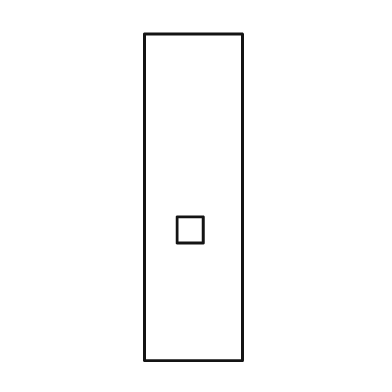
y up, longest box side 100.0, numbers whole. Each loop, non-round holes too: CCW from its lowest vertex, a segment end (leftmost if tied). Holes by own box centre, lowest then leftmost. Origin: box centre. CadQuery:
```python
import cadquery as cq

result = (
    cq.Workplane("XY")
    .moveTo(-15.0, -50.0)
    .lineTo(15.0, -50.0)
    .lineTo(15.0, 50.0)
    .lineTo(-15.0, 50.0)
    .close()
    .moveTo(-5.0, -14.0)
    .lineTo(3.0, -14.0)
    .lineTo(3.0, -6.0)
    .lineTo(-5.0, -6.0)
    .close()
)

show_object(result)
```